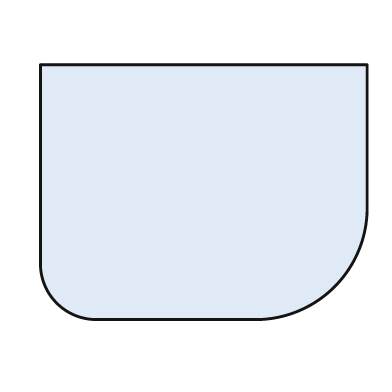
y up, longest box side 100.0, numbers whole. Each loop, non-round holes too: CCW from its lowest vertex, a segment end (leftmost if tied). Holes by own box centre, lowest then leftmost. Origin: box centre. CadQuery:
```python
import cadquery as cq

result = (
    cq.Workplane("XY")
    .moveTo(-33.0, -39.0)
    .lineTo(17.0, -39.0)
    .threePointArc((40.0, -29.0), (50.0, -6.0))
    .lineTo(50.0, 39.0)
    .lineTo(-50.0, 39.0)
    .lineTo(-50.0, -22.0)
    .threePointArc((-45.0, -34.0), (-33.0, -39.0))
    .close()
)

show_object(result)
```